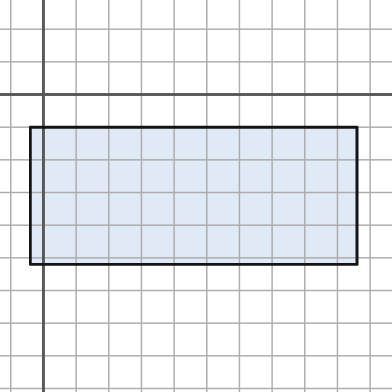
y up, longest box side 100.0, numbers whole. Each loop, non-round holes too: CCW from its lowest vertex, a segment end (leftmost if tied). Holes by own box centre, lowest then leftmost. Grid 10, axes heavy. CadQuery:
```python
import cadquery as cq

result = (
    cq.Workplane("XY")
    .moveTo(-4.0, -52.0)
    .lineTo(96.0, -52.0)
    .lineTo(96.0, -10.0)
    .lineTo(-4.0, -10.0)
    .close()
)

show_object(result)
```